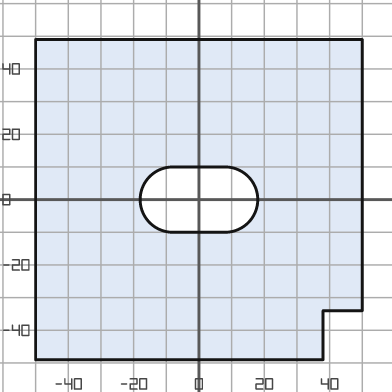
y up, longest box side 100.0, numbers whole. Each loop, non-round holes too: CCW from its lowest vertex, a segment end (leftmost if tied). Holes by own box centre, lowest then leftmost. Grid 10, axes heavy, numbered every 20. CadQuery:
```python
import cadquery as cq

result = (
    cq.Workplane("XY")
    .moveTo(-50.0, -49.0)
    .lineTo(38.0, -49.0)
    .lineTo(38.0, -34.0)
    .lineTo(50.0, -34.0)
    .lineTo(50.0, 49.0)
    .lineTo(-50.0, 49.0)
    .close()
    .moveTo(-8.0, -10.0)
    .lineTo(8.0, -10.0)
    .threePointArc((18.0, 0.0), (8.0, 10.0))
    .lineTo(-8.0, 10.0)
    .threePointArc((-18.0, 0.0), (-8.0, -10.0))
    .close()
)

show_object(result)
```